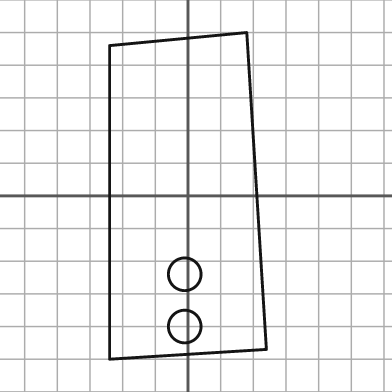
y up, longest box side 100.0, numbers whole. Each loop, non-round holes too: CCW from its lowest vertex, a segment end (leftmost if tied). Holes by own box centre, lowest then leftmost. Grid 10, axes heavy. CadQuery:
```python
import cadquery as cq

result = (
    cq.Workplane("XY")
    .moveTo(-24.0, -50.0)
    .lineTo(24.0, -47.0)
    .lineTo(18.0, 50.0)
    .lineTo(-24.0, 46.0)
    .close()
    .moveTo(-1.0, -40.0)
    .circle(5.0)
    .moveTo(-1.0, -24.0)
    .circle(5.0)
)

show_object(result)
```